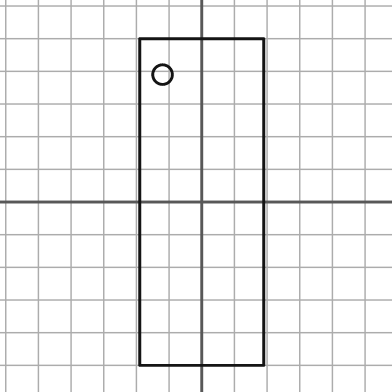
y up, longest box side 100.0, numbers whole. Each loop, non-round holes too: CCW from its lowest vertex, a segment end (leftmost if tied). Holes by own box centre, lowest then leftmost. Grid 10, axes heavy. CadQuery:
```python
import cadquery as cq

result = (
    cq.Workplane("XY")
    .moveTo(-19.0, -50.0)
    .lineTo(19.0, -50.0)
    .lineTo(19.0, 50.0)
    .lineTo(-19.0, 50.0)
    .close()
    .moveTo(-12.0, 39.0)
    .circle(3.0)
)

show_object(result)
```